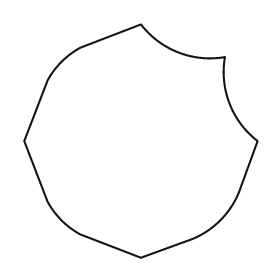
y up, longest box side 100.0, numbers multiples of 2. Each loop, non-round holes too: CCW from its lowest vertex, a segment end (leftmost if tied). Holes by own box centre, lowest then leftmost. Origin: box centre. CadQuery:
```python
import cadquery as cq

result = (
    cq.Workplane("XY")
    .moveTo(0.0, -50.0)
    .lineTo(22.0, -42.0)
    .threePointArc((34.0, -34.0), (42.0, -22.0))
    .lineTo(50.0, 0.0)
    .threePointArc((38.0, 16.0), (36.0, 36.0))
    .threePointArc((16.0, 38.0), (0.0, 50.0))
    .lineTo(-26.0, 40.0)
    .threePointArc((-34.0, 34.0), (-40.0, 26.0))
    .lineTo(-50.0, 0.0)
    .lineTo(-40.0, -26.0)
    .threePointArc((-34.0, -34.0), (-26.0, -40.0))
    .close()
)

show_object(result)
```